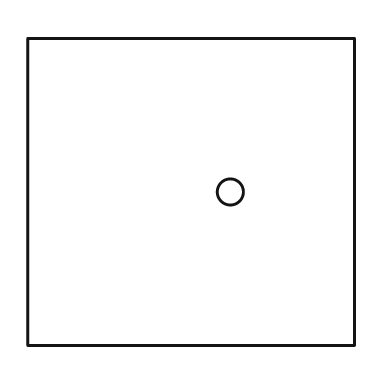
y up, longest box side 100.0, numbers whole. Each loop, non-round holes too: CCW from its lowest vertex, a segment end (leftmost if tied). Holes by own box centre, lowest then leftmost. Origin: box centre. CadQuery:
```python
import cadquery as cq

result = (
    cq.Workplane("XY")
    .moveTo(-50.0, -47.0)
    .lineTo(50.0, -47.0)
    .lineTo(50.0, 47.0)
    .lineTo(-50.0, 47.0)
    .close()
    .moveTo(12.0, 0.0)
    .circle(4.0)
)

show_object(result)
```